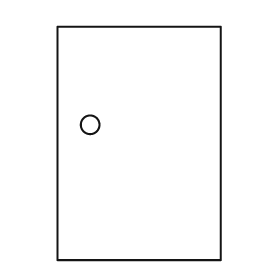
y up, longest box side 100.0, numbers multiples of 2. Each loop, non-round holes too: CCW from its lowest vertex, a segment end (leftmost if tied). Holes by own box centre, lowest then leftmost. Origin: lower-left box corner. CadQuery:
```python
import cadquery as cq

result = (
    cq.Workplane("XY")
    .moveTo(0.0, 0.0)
    .lineTo(70.0, 0.0)
    .lineTo(70.0, 100.0)
    .lineTo(0.0, 100.0)
    .close()
    .moveTo(14.0, 58.0)
    .circle(4.0)
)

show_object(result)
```